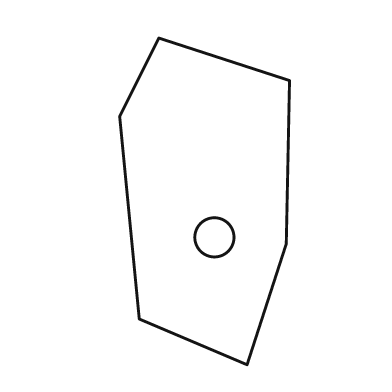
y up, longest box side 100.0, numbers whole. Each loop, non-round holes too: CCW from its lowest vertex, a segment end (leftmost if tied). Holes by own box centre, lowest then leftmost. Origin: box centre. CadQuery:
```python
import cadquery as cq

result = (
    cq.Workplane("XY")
    .moveTo(13.0, -50.0)
    .lineTo(25.0, -13.0)
    .lineTo(26.0, 37.0)
    .lineTo(-14.0, 50.0)
    .lineTo(-26.0, 26.0)
    .lineTo(-20.0, -36.0)
    .close()
    .moveTo(3.0, -11.0)
    .circle(6.0)
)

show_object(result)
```